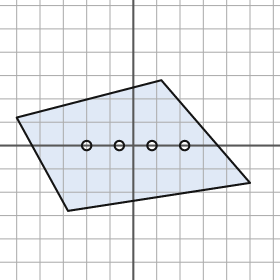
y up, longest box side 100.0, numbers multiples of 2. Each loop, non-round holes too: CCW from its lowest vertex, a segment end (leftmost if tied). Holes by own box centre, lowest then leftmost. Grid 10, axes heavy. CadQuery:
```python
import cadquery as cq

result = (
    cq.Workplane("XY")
    .moveTo(-28.0, -28.0)
    .lineTo(50.0, -16.0)
    .lineTo(12.0, 28.0)
    .lineTo(-50.0, 12.0)
    .close()
    .moveTo(-20.0, 0.0)
    .circle(2.0)
    .moveTo(-6.0, 0.0)
    .circle(2.0)
    .moveTo(8.0, 0.0)
    .circle(2.0)
    .moveTo(22.0, 0.0)
    .circle(2.0)
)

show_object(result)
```